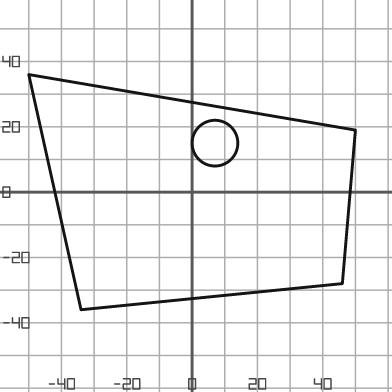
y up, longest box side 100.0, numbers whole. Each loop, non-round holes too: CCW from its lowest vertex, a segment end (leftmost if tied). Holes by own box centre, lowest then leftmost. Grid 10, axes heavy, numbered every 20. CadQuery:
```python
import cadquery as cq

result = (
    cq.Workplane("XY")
    .moveTo(-34.0, -36.0)
    .lineTo(46.0, -28.0)
    .lineTo(50.0, 19.0)
    .lineTo(-50.0, 36.0)
    .close()
    .moveTo(7.0, 15.0)
    .circle(7.0)
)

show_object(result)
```